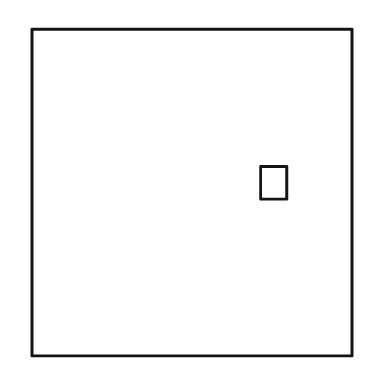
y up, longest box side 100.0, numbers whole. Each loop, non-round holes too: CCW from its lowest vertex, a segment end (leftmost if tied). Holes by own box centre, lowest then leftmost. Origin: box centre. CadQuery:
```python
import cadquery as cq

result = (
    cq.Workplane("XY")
    .moveTo(-49.0, -50.0)
    .lineTo(49.0, -50.0)
    .lineTo(49.0, 50.0)
    .lineTo(-49.0, 50.0)
    .close()
    .moveTo(21.0, -2.0)
    .lineTo(29.0, -2.0)
    .lineTo(29.0, 8.0)
    .lineTo(21.0, 8.0)
    .close()
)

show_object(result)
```